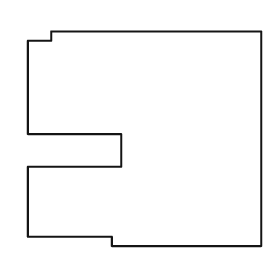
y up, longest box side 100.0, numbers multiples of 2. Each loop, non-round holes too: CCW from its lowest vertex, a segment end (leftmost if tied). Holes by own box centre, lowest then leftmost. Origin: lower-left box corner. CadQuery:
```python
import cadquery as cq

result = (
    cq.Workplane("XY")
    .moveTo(36.0, 0.0)
    .lineTo(100.0, 0.0)
    .lineTo(100.0, 92.0)
    .lineTo(10.0, 92.0)
    .lineTo(10.0, 88.0)
    .lineTo(0.0, 88.0)
    .lineTo(0.0, 48.0)
    .lineTo(40.0, 48.0)
    .lineTo(40.0, 34.0)
    .lineTo(0.0, 34.0)
    .lineTo(0.0, 4.0)
    .lineTo(36.0, 4.0)
    .close()
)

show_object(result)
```